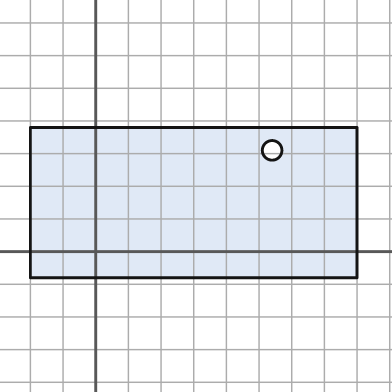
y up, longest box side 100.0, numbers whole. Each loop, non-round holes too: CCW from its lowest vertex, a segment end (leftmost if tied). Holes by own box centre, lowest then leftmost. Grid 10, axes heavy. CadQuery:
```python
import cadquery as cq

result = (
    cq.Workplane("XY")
    .moveTo(-20.0, -8.0)
    .lineTo(80.0, -8.0)
    .lineTo(80.0, 38.0)
    .lineTo(-20.0, 38.0)
    .close()
    .moveTo(54.0, 31.0)
    .circle(3.0)
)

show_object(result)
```